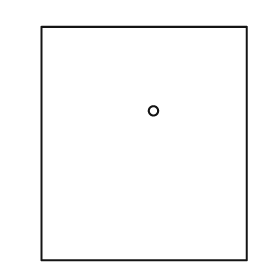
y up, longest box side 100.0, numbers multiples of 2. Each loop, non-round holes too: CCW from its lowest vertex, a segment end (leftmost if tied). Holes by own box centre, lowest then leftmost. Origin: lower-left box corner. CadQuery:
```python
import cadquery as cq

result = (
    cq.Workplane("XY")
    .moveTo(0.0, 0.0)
    .lineTo(88.0, 0.0)
    .lineTo(88.0, 100.0)
    .lineTo(0.0, 100.0)
    .close()
    .moveTo(48.0, 64.0)
    .circle(2.0)
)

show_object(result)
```